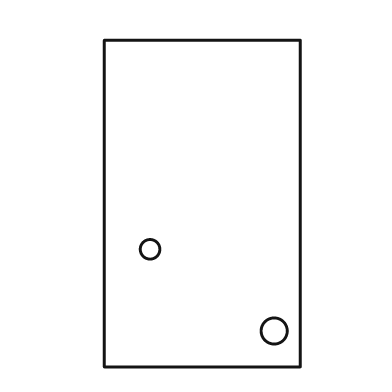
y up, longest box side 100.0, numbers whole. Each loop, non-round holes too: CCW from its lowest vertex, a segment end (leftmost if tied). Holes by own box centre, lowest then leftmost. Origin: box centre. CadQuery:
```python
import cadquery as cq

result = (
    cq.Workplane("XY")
    .moveTo(-30.0, -50.0)
    .lineTo(30.0, -50.0)
    .lineTo(30.0, 50.0)
    .lineTo(-30.0, 50.0)
    .close()
    .moveTo(22.0, -39.0)
    .circle(4.0)
    .moveTo(-16.0, -14.0)
    .circle(3.0)
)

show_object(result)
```